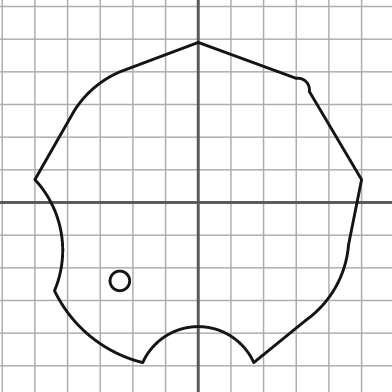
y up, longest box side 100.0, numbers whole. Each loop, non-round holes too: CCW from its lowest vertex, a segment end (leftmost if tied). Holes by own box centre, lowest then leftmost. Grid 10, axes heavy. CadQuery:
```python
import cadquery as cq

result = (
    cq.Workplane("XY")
    .moveTo(-17.0, -49.0)
    .threePointArc((0.0, -38.0), (17.0, -49.0))
    .lineTo(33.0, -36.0)
    .threePointArc((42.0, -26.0), (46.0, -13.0))
    .lineTo(50.0, 7.0)
    .lineTo(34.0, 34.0)
    .threePointArc((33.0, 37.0), (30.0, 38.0))
    .lineTo(0.0, 49.0)
    .lineTo(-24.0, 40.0)
    .threePointArc((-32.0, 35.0), (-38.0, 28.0))
    .lineTo(-50.0, 7.0)
    .threePointArc((-42.0, -9.0), (-44.0, -27.0))
    .threePointArc((-33.0, -41.0), (-17.0, -49.0))
    .close()
    .moveTo(-24.0, -24.0)
    .circle(3.0)
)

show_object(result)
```